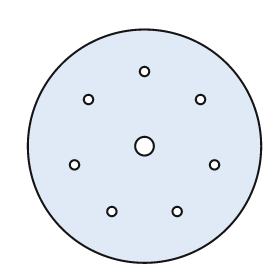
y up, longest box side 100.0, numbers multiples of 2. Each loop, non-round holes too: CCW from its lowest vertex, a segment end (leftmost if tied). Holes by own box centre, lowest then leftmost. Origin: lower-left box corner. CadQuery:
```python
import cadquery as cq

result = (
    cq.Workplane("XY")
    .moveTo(50.0, 50.0)
    .circle(50.0)
    .moveTo(36.0, 22.0)
    .circle(2.0)
    .moveTo(64.0, 22.0)
    .circle(2.0)
    .moveTo(20.0, 42.0)
    .circle(2.0)
    .moveTo(80.0, 42.0)
    .circle(2.0)
    .moveTo(50.0, 50.0)
    .circle(4.0)
    .moveTo(26.0, 70.0)
    .circle(2.0)
    .moveTo(74.0, 70.0)
    .circle(2.0)
    .moveTo(50.0, 82.0)
    .circle(2.0)
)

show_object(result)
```